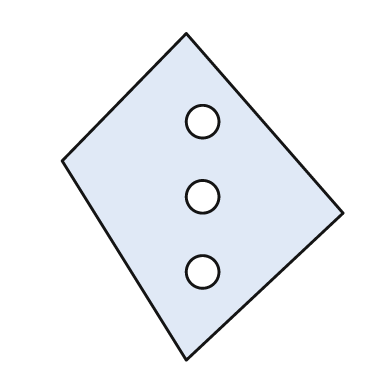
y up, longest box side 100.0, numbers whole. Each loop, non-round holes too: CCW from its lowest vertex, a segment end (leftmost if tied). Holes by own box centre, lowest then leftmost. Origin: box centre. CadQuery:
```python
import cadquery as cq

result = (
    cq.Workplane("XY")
    .moveTo(-5.0, -50.0)
    .lineTo(43.0, -5.0)
    .lineTo(-5.0, 50.0)
    .lineTo(-43.0, 11.0)
    .close()
    .moveTo(0.0, -23.0)
    .circle(5.0)
    .moveTo(0.0, 0.0)
    .circle(5.0)
    .moveTo(0.0, 23.0)
    .circle(5.0)
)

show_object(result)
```